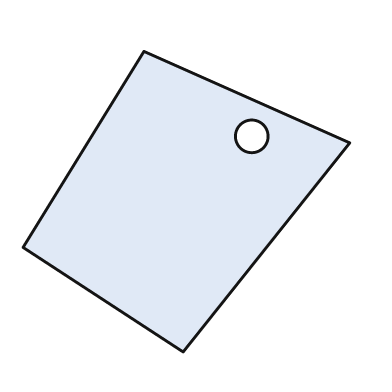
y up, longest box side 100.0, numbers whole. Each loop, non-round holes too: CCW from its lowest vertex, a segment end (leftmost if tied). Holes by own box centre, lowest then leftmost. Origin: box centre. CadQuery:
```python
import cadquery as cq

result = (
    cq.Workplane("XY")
    .moveTo(-1.0, -46.0)
    .lineTo(50.0, 18.0)
    .lineTo(-13.0, 46.0)
    .lineTo(-50.0, -14.0)
    .close()
    .moveTo(20.0, 20.0)
    .circle(5.0)
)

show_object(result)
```